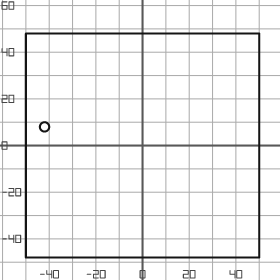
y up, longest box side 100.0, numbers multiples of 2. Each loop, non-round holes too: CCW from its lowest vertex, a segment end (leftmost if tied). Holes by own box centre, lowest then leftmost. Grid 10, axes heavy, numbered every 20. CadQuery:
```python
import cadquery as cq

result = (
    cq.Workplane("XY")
    .moveTo(-50.0, -48.0)
    .lineTo(50.0, -48.0)
    .lineTo(50.0, 48.0)
    .lineTo(-50.0, 48.0)
    .close()
    .moveTo(-42.0, 8.0)
    .circle(2.0)
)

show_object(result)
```